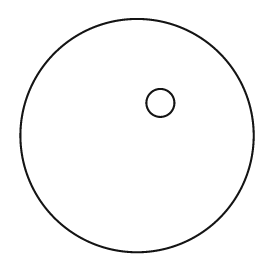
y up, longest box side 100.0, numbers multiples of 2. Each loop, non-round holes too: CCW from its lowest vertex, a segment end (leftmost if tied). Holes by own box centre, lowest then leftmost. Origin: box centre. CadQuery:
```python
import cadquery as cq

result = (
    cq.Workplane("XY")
    .moveTo(0.0, 0.0)
    .circle(50.0)
    .moveTo(10.0, 14.0)
    .circle(6.0)
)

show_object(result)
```